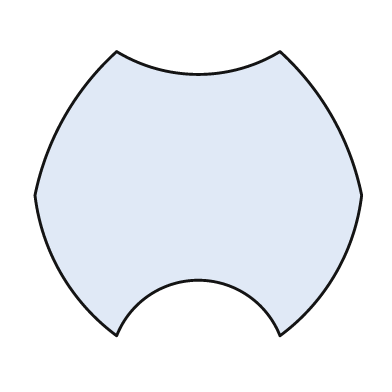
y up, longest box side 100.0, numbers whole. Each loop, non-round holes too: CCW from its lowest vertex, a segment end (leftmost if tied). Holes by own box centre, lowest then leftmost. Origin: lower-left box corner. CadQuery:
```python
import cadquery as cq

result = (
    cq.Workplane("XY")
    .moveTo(25.0, 0.0)
    .threePointArc((50.0, 17.0), (75.0, 0.0))
    .threePointArc((92.0, 19.0), (100.0, 43.0))
    .threePointArc((91.0, 67.0), (75.0, 87.0))
    .threePointArc((50.0, 80.0), (25.0, 87.0))
    .threePointArc((9.0, 67.0), (0.0, 43.0))
    .threePointArc((8.0, 19.0), (25.0, 0.0))
    .close()
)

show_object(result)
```